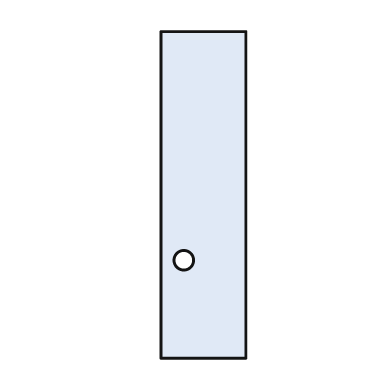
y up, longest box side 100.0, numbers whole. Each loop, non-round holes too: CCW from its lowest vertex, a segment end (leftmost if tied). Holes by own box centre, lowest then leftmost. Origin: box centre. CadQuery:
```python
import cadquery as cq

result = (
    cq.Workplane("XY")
    .moveTo(-13.0, -50.0)
    .lineTo(13.0, -50.0)
    .lineTo(13.0, 50.0)
    .lineTo(-13.0, 50.0)
    .close()
    .moveTo(-6.0, -20.0)
    .circle(3.0)
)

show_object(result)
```